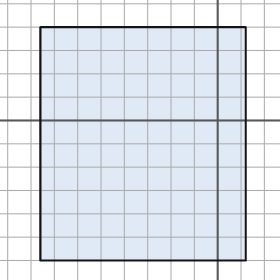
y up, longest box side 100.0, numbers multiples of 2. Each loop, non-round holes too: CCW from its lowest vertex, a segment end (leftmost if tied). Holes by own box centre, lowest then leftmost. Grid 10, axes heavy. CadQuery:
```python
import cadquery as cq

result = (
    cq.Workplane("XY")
    .moveTo(-76.0, -60.0)
    .lineTo(12.0, -60.0)
    .lineTo(12.0, 40.0)
    .lineTo(-76.0, 40.0)
    .close()
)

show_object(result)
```